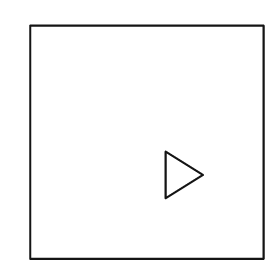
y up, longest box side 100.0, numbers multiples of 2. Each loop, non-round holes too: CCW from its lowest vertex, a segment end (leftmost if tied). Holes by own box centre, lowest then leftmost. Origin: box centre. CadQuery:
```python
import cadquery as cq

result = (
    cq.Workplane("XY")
    .moveTo(-50.0, -50.0)
    .lineTo(50.0, -50.0)
    .lineTo(50.0, 50.0)
    .lineTo(-50.0, 50.0)
    .close()
    .moveTo(8.0, -24.0)
    .lineTo(24.0, -14.0)
    .lineTo(8.0, -4.0)
    .close()
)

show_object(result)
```